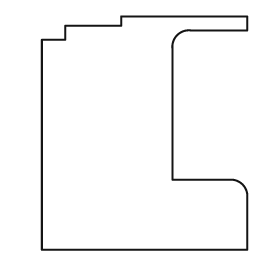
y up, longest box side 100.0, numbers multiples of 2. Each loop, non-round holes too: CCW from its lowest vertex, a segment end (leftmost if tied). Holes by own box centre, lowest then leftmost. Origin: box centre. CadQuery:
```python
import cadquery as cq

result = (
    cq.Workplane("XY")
    .moveTo(-44.0, -50.0)
    .lineTo(44.0, -50.0)
    .lineTo(44.0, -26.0)
    .threePointArc((42.0, -22.0), (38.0, -20.0))
    .lineTo(12.0, -20.0)
    .lineTo(12.0, 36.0)
    .threePointArc((14.0, 42.0), (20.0, 44.0))
    .lineTo(44.0, 44.0)
    .lineTo(44.0, 50.0)
    .lineTo(-10.0, 50.0)
    .lineTo(-10.0, 46.0)
    .lineTo(-34.0, 46.0)
    .lineTo(-34.0, 40.0)
    .lineTo(-44.0, 40.0)
    .close()
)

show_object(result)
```